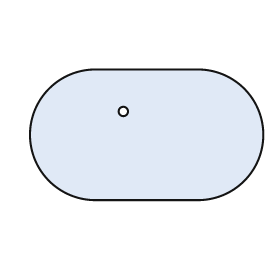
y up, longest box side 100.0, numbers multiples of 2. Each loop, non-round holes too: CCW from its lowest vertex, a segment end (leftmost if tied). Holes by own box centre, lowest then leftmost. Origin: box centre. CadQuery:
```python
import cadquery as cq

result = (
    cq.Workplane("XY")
    .moveTo(-22.0, -28.0)
    .lineTo(22.0, -28.0)
    .threePointArc((50.0, 0.0), (22.0, 28.0))
    .lineTo(-22.0, 28.0)
    .threePointArc((-50.0, 0.0), (-22.0, -28.0))
    .close()
    .moveTo(-10.0, 10.0)
    .circle(2.0)
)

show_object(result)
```